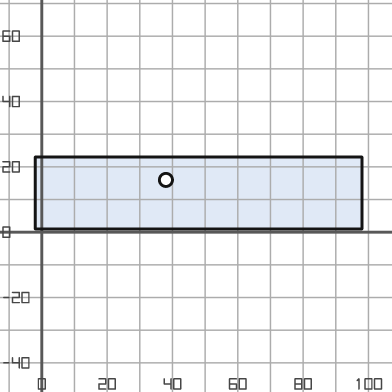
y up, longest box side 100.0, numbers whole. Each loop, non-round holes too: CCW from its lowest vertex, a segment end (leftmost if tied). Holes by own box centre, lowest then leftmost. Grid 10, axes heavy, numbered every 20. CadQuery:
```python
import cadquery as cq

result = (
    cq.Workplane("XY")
    .moveTo(-2.0, 1.0)
    .lineTo(98.0, 1.0)
    .lineTo(98.0, 23.0)
    .lineTo(-2.0, 23.0)
    .close()
    .moveTo(38.0, 16.0)
    .circle(2.0)
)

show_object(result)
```